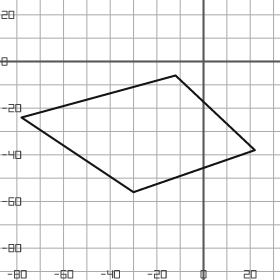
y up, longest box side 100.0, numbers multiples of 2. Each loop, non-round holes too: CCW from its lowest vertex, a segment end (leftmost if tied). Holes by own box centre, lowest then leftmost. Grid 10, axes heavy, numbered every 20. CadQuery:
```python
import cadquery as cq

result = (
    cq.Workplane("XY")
    .moveTo(-30.0, -56.0)
    .lineTo(22.0, -38.0)
    .lineTo(-12.0, -6.0)
    .lineTo(-78.0, -24.0)
    .close()
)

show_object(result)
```